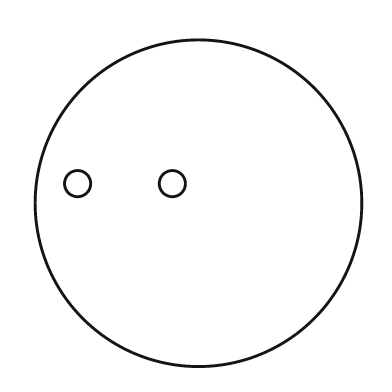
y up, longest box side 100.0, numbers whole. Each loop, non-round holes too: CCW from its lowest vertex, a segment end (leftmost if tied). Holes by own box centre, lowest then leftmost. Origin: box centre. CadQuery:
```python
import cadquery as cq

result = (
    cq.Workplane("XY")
    .moveTo(0.0, 0.0)
    .circle(50.0)
    .moveTo(-37.0, 6.0)
    .circle(4.0)
    .moveTo(-8.0, 6.0)
    .circle(4.0)
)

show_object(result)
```